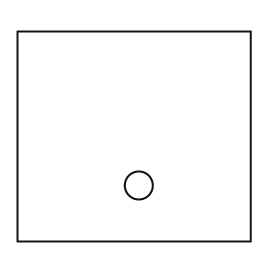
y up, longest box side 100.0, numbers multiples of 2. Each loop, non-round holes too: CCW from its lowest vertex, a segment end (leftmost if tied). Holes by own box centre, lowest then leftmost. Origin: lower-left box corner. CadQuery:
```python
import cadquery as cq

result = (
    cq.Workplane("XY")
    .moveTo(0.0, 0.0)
    .lineTo(100.0, 0.0)
    .lineTo(100.0, 90.0)
    .lineTo(0.0, 90.0)
    .close()
    .moveTo(52.0, 24.0)
    .circle(6.0)
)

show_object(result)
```